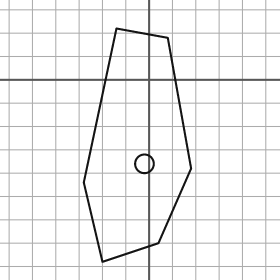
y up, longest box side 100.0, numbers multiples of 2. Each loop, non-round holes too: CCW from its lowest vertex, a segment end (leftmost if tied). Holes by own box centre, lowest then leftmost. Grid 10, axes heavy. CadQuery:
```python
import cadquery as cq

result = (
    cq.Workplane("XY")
    .moveTo(-20.0, -78.0)
    .lineTo(4.0, -70.0)
    .lineTo(18.0, -38.0)
    .lineTo(8.0, 18.0)
    .lineTo(-14.0, 22.0)
    .lineTo(-28.0, -44.0)
    .close()
    .moveTo(-2.0, -36.0)
    .circle(4.0)
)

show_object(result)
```